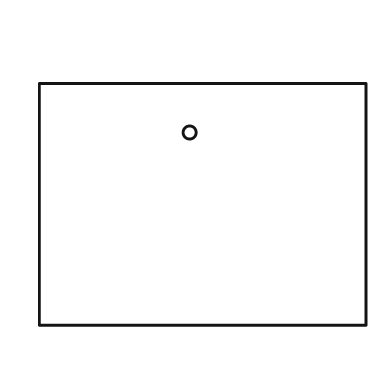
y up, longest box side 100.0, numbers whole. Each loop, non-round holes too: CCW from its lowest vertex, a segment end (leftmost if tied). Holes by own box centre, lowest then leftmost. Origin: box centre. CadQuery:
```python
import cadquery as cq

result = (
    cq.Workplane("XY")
    .moveTo(-50.0, -37.0)
    .lineTo(50.0, -37.0)
    .lineTo(50.0, 37.0)
    .lineTo(-50.0, 37.0)
    .close()
    .moveTo(-4.0, 22.0)
    .circle(2.0)
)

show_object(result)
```